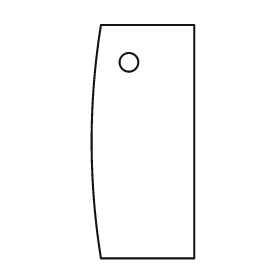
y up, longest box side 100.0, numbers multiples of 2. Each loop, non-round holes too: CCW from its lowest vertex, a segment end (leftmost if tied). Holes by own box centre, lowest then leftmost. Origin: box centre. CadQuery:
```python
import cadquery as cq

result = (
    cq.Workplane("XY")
    .moveTo(-18.0, -50.0)
    .lineTo(22.0, -50.0)
    .lineTo(22.0, 50.0)
    .lineTo(-18.0, 50.0)
    .threePointArc((-22.0, 0.0), (-18.0, -50.0))
    .close()
    .moveTo(-6.0, 34.0)
    .circle(4.0)
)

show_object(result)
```